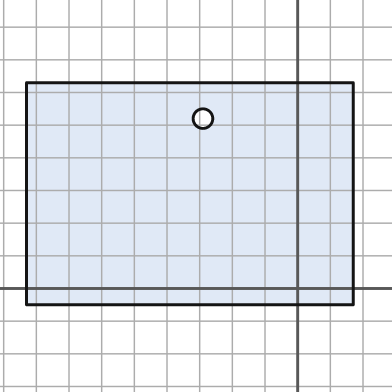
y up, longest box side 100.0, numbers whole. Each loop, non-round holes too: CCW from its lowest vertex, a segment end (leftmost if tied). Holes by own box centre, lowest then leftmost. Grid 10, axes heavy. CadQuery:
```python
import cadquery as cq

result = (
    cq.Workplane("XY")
    .moveTo(-83.0, -5.0)
    .lineTo(17.0, -5.0)
    .lineTo(17.0, 63.0)
    .lineTo(-83.0, 63.0)
    .close()
    .moveTo(-29.0, 52.0)
    .circle(3.0)
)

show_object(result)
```